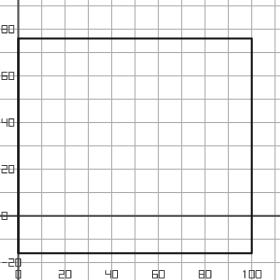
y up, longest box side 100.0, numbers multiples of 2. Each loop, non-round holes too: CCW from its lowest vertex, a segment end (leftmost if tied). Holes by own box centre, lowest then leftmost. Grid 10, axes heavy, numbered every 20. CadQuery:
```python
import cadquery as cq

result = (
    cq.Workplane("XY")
    .moveTo(0.0, -16.0)
    .lineTo(100.0, -16.0)
    .lineTo(100.0, 76.0)
    .lineTo(0.0, 76.0)
    .close()
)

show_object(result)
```